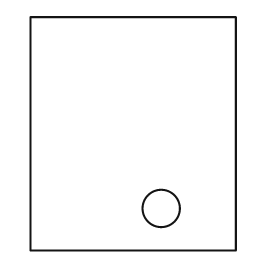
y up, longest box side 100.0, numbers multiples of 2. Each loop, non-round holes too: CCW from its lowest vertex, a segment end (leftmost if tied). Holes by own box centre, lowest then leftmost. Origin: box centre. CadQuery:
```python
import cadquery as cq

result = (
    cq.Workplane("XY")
    .moveTo(-44.0, -50.0)
    .lineTo(44.0, -50.0)
    .lineTo(44.0, 50.0)
    .lineTo(-44.0, 50.0)
    .close()
    .moveTo(12.0, -32.0)
    .circle(8.0)
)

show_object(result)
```